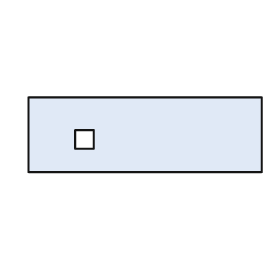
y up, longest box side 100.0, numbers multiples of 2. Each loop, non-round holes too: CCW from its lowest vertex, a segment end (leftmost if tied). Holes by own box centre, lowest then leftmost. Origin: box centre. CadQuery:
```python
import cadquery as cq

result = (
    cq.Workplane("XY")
    .moveTo(-50.0, -16.0)
    .lineTo(50.0, -16.0)
    .lineTo(50.0, 16.0)
    .lineTo(-50.0, 16.0)
    .close()
    .moveTo(-30.0, -6.0)
    .lineTo(-22.0, -6.0)
    .lineTo(-22.0, 2.0)
    .lineTo(-30.0, 2.0)
    .close()
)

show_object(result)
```